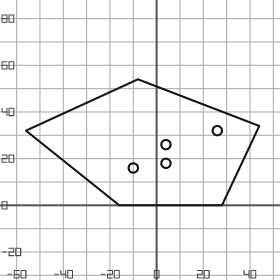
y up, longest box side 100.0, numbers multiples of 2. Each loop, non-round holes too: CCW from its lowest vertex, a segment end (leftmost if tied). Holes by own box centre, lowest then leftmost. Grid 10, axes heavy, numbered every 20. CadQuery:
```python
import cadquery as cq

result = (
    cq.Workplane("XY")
    .moveTo(-16.0, 0.0)
    .lineTo(28.0, 0.0)
    .lineTo(44.0, 34.0)
    .lineTo(-8.0, 54.0)
    .lineTo(-56.0, 32.0)
    .close()
    .moveTo(-10.0, 16.0)
    .circle(2.0)
    .moveTo(4.0, 18.0)
    .circle(2.0)
    .moveTo(4.0, 26.0)
    .circle(2.0)
    .moveTo(26.0, 32.0)
    .circle(2.0)
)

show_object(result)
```